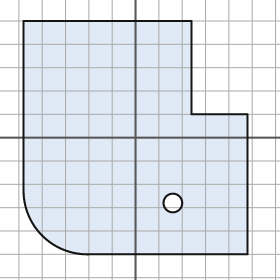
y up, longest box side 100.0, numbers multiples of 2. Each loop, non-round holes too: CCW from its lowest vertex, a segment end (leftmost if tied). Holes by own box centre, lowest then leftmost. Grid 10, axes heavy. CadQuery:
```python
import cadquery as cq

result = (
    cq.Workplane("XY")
    .moveTo(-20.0, -50.0)
    .lineTo(48.0, -50.0)
    .lineTo(48.0, 10.0)
    .lineTo(24.0, 10.0)
    .lineTo(24.0, 50.0)
    .lineTo(-48.0, 50.0)
    .lineTo(-48.0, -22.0)
    .threePointArc((-40.0, -42.0), (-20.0, -50.0))
    .close()
    .moveTo(16.0, -28.0)
    .circle(4.0)
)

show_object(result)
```